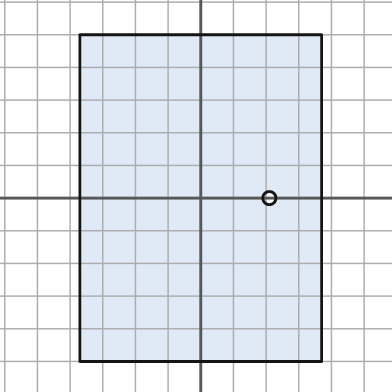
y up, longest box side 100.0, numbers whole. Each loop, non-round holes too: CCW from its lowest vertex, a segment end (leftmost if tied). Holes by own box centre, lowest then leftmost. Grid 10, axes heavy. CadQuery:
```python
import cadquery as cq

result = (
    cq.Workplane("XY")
    .moveTo(-37.0, -50.0)
    .lineTo(37.0, -50.0)
    .lineTo(37.0, 50.0)
    .lineTo(-37.0, 50.0)
    .close()
    .moveTo(21.0, 0.0)
    .circle(2.0)
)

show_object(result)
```